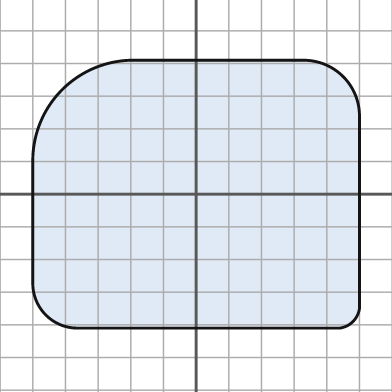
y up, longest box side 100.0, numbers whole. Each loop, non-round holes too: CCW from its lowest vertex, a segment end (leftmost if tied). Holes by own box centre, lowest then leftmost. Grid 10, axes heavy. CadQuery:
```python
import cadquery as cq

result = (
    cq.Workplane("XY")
    .moveTo(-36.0, -41.0)
    .lineTo(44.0, -41.0)
    .threePointArc((48.0, -39.0), (50.0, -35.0))
    .lineTo(50.0, 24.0)
    .threePointArc((45.0, 36.0), (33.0, 41.0))
    .lineTo(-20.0, 41.0)
    .threePointArc((-41.0, 32.0), (-50.0, 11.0))
    .lineTo(-50.0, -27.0)
    .threePointArc((-46.0, -37.0), (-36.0, -41.0))
    .close()
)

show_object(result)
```